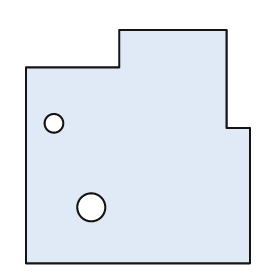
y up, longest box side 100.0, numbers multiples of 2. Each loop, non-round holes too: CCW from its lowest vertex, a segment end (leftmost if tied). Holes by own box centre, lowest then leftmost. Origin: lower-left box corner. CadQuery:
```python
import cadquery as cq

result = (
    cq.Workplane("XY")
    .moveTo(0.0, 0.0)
    .lineTo(96.0, 0.0)
    .lineTo(96.0, 58.0)
    .lineTo(86.0, 58.0)
    .lineTo(86.0, 100.0)
    .lineTo(40.0, 100.0)
    .lineTo(40.0, 84.0)
    .lineTo(0.0, 84.0)
    .close()
    .moveTo(28.0, 24.0)
    .circle(6.0)
    .moveTo(12.0, 60.0)
    .circle(4.0)
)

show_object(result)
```